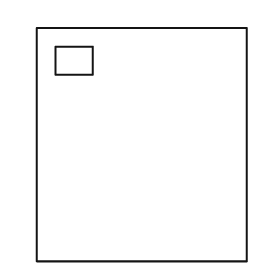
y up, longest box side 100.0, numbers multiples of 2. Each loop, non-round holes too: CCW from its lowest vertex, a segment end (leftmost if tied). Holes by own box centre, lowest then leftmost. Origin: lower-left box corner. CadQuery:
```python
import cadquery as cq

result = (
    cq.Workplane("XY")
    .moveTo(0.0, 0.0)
    .lineTo(90.0, 0.0)
    .lineTo(90.0, 100.0)
    .lineTo(0.0, 100.0)
    .close()
    .moveTo(8.0, 80.0)
    .lineTo(24.0, 80.0)
    .lineTo(24.0, 92.0)
    .lineTo(8.0, 92.0)
    .close()
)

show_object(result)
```